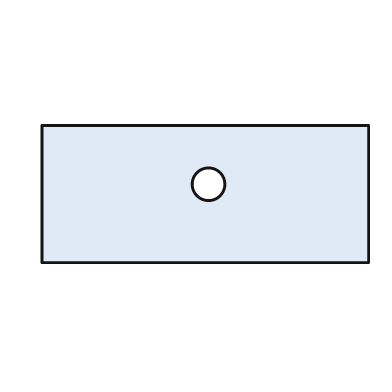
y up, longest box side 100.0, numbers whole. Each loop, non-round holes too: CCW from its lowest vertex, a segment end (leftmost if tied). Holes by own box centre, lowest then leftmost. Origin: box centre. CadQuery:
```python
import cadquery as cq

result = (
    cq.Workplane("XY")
    .moveTo(-50.0, -21.0)
    .lineTo(50.0, -21.0)
    .lineTo(50.0, 21.0)
    .lineTo(-50.0, 21.0)
    .close()
    .moveTo(1.0, 3.0)
    .circle(5.0)
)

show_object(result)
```